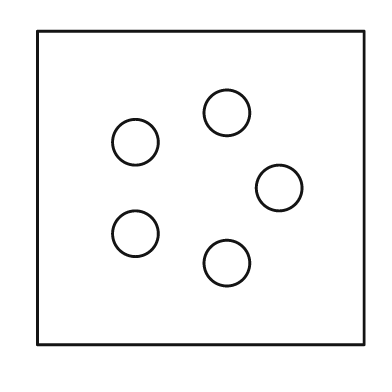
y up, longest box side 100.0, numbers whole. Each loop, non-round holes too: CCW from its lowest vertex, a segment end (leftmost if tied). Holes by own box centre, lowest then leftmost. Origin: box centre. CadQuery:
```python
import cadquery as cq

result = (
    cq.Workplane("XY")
    .moveTo(-50.0, -48.0)
    .lineTo(50.0, -48.0)
    .lineTo(50.0, 48.0)
    .lineTo(-50.0, 48.0)
    .close()
    .moveTo(8.0, -23.0)
    .circle(7.0)
    .moveTo(-20.0, -14.0)
    .circle(7.0)
    .moveTo(24.0, 0.0)
    .circle(7.0)
    .moveTo(-20.0, 14.0)
    .circle(7.0)
    .moveTo(8.0, 23.0)
    .circle(7.0)
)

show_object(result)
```